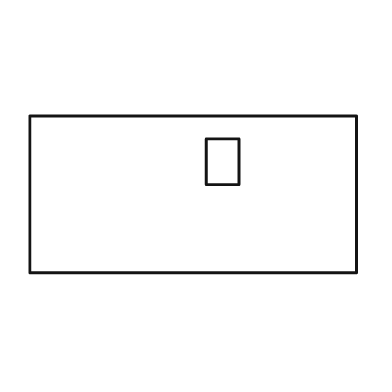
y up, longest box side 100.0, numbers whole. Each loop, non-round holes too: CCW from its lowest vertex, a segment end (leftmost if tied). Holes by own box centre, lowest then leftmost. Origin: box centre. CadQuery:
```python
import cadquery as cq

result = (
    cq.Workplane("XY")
    .moveTo(-50.0, -24.0)
    .lineTo(50.0, -24.0)
    .lineTo(50.0, 24.0)
    .lineTo(-50.0, 24.0)
    .close()
    .moveTo(4.0, 3.0)
    .lineTo(14.0, 3.0)
    .lineTo(14.0, 17.0)
    .lineTo(4.0, 17.0)
    .close()
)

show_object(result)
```